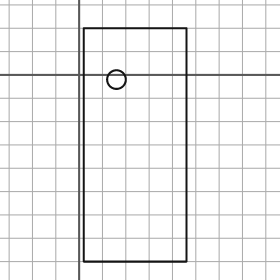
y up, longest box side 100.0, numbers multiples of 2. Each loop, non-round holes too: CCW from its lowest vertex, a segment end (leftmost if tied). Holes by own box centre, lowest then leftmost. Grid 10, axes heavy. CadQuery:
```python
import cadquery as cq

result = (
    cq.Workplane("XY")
    .moveTo(2.0, -80.0)
    .lineTo(46.0, -80.0)
    .lineTo(46.0, 20.0)
    .lineTo(2.0, 20.0)
    .close()
    .moveTo(16.0, -2.0)
    .circle(4.0)
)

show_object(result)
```